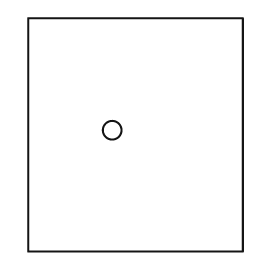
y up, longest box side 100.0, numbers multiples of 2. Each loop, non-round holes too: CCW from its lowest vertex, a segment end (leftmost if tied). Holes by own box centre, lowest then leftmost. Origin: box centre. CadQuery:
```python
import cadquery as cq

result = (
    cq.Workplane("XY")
    .moveTo(-46.0, -50.0)
    .lineTo(46.0, -50.0)
    .lineTo(46.0, 50.0)
    .lineTo(-46.0, 50.0)
    .close()
    .moveTo(-10.0, 2.0)
    .circle(4.0)
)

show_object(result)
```